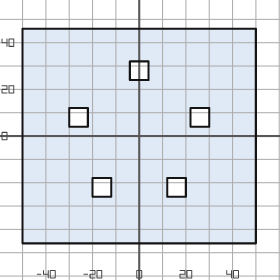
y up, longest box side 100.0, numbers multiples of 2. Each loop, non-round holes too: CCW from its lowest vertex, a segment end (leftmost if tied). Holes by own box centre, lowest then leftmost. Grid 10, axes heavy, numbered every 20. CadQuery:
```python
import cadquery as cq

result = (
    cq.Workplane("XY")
    .moveTo(-50.0, -46.0)
    .lineTo(50.0, -46.0)
    .lineTo(50.0, 46.0)
    .lineTo(-50.0, 46.0)
    .close()
    .moveTo(-20.0, -26.0)
    .lineTo(-12.0, -26.0)
    .lineTo(-12.0, -18.0)
    .lineTo(-20.0, -18.0)
    .close()
    .moveTo(12.0, -26.0)
    .lineTo(20.0, -26.0)
    .lineTo(20.0, -18.0)
    .lineTo(12.0, -18.0)
    .close()
    .moveTo(-30.0, 4.0)
    .lineTo(-22.0, 4.0)
    .lineTo(-22.0, 12.0)
    .lineTo(-30.0, 12.0)
    .close()
    .moveTo(22.0, 4.0)
    .lineTo(30.0, 4.0)
    .lineTo(30.0, 12.0)
    .lineTo(22.0, 12.0)
    .close()
    .moveTo(-4.0, 24.0)
    .lineTo(4.0, 24.0)
    .lineTo(4.0, 32.0)
    .lineTo(-4.0, 32.0)
    .close()
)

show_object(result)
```